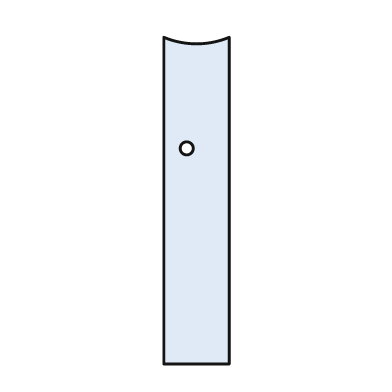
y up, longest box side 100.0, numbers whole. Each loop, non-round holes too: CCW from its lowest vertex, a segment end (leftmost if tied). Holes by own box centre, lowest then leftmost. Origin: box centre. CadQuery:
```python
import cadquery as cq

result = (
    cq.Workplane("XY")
    .moveTo(-10.0, -50.0)
    .lineTo(10.0, -50.0)
    .lineTo(10.0, 50.0)
    .threePointArc((0.0, 48.0), (-10.0, 50.0))
    .close()
    .moveTo(-3.0, 16.0)
    .circle(2.0)
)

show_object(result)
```